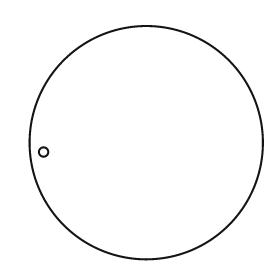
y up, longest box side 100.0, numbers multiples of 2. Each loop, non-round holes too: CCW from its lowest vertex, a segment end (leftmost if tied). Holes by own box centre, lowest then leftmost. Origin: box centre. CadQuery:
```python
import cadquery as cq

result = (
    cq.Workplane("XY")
    .moveTo(0.0, 0.0)
    .circle(50.0)
    .moveTo(-44.0, -4.0)
    .circle(2.0)
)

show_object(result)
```